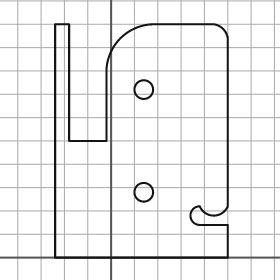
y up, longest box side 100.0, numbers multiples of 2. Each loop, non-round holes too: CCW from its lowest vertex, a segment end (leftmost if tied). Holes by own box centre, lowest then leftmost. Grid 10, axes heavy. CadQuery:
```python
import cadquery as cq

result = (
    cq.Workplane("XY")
    .moveTo(-24.0, 0.0)
    .lineTo(50.0, 0.0)
    .lineTo(50.0, 14.0)
    .lineTo(38.0, 14.0)
    .threePointArc((34.0, 18.0), (38.0, 22.0))
    .threePointArc((44.0, 18.0), (50.0, 22.0))
    .lineTo(50.0, 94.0)
    .threePointArc((48.0, 98.0), (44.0, 100.0))
    .lineTo(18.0, 100.0)
    .threePointArc((4.0, 94.0), (-2.0, 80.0))
    .lineTo(-2.0, 50.0)
    .lineTo(-18.0, 50.0)
    .lineTo(-18.0, 100.0)
    .lineTo(-24.0, 100.0)
    .close()
    .moveTo(14.0, 28.0)
    .circle(4.0)
    .moveTo(14.0, 72.0)
    .circle(4.0)
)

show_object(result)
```